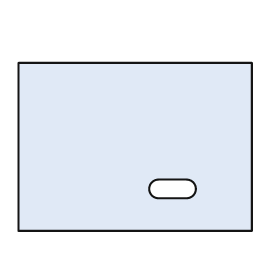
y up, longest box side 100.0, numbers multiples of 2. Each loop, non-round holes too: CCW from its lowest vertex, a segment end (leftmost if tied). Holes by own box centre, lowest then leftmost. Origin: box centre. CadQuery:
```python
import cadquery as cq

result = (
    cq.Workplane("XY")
    .moveTo(-50.0, -36.0)
    .lineTo(50.0, -36.0)
    .lineTo(50.0, 36.0)
    .lineTo(-50.0, 36.0)
    .close()
    .moveTo(10.0, -22.0)
    .lineTo(22.0, -22.0)
    .threePointArc((26.0, -18.0), (22.0, -14.0))
    .lineTo(10.0, -14.0)
    .threePointArc((6.0, -18.0), (10.0, -22.0))
    .close()
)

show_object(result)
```